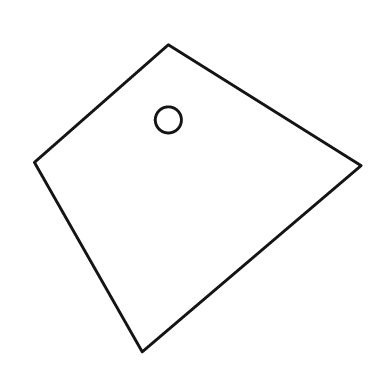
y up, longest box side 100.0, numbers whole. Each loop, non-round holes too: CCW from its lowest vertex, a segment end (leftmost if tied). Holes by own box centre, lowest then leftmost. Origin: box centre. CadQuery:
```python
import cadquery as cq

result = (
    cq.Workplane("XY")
    .moveTo(-17.0, -47.0)
    .lineTo(50.0, 10.0)
    .lineTo(-9.0, 47.0)
    .lineTo(-50.0, 11.0)
    .close()
    .moveTo(-9.0, 24.0)
    .circle(4.0)
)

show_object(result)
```